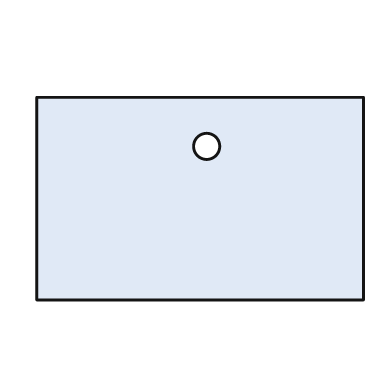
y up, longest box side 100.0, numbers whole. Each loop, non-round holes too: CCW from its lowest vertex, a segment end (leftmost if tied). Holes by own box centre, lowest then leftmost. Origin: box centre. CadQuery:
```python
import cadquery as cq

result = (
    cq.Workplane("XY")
    .moveTo(-50.0, -31.0)
    .lineTo(50.0, -31.0)
    .lineTo(50.0, 31.0)
    .lineTo(-50.0, 31.0)
    .close()
    .moveTo(2.0, 16.0)
    .circle(4.0)
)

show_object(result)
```